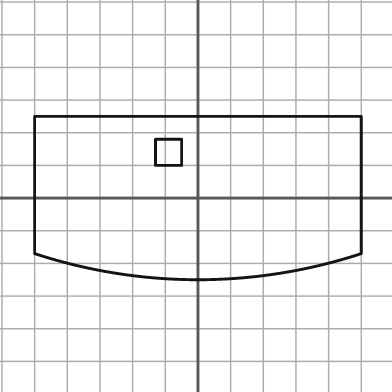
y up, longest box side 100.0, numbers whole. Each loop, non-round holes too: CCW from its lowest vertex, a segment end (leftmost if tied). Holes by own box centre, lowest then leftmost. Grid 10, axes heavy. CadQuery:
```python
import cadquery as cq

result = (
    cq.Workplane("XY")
    .moveTo(-50.0, -17.0)
    .threePointArc((0.0, -25.0), (50.0, -17.0))
    .lineTo(50.0, 25.0)
    .lineTo(-50.0, 25.0)
    .close()
    .moveTo(-13.0, 10.0)
    .lineTo(-5.0, 10.0)
    .lineTo(-5.0, 18.0)
    .lineTo(-13.0, 18.0)
    .close()
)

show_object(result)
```